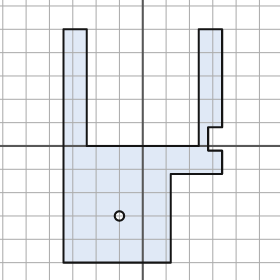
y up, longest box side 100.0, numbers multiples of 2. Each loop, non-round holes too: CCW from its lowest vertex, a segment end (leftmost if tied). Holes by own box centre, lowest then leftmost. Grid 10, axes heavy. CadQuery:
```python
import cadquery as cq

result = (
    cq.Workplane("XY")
    .moveTo(-34.0, -50.0)
    .lineTo(12.0, -50.0)
    .lineTo(12.0, -12.0)
    .lineTo(34.0, -12.0)
    .lineTo(34.0, -2.0)
    .lineTo(28.0, -2.0)
    .lineTo(28.0, 8.0)
    .lineTo(34.0, 8.0)
    .lineTo(34.0, 50.0)
    .lineTo(24.0, 50.0)
    .lineTo(24.0, 0.0)
    .lineTo(-24.0, 0.0)
    .lineTo(-24.0, 50.0)
    .lineTo(-34.0, 50.0)
    .close()
    .moveTo(-10.0, -30.0)
    .circle(2.0)
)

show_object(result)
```